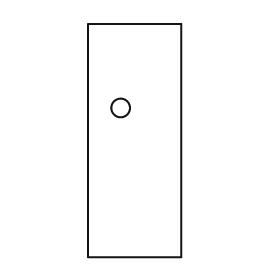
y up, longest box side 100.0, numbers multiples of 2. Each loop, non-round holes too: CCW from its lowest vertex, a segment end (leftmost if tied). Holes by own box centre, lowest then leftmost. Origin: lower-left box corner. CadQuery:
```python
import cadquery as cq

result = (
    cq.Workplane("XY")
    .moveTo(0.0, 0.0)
    .lineTo(40.0, 0.0)
    .lineTo(40.0, 100.0)
    .lineTo(0.0, 100.0)
    .close()
    .moveTo(14.0, 64.0)
    .circle(4.0)
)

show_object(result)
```